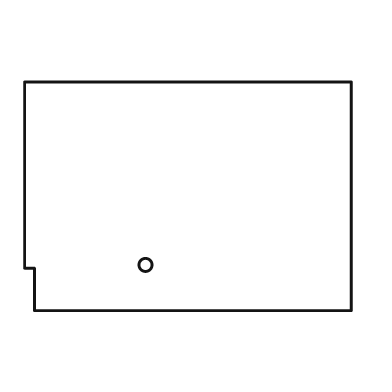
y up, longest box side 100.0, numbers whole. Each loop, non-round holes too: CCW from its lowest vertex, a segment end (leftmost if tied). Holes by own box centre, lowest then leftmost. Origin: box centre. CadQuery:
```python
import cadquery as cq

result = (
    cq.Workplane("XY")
    .moveTo(-47.0, -35.0)
    .lineTo(50.0, -35.0)
    .lineTo(50.0, 35.0)
    .lineTo(-50.0, 35.0)
    .lineTo(-50.0, -22.0)
    .lineTo(-47.0, -22.0)
    .close()
    .moveTo(-13.0, -21.0)
    .circle(2.0)
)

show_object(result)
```